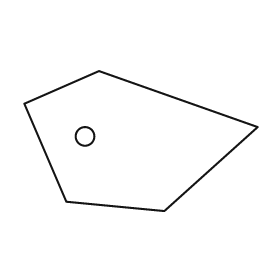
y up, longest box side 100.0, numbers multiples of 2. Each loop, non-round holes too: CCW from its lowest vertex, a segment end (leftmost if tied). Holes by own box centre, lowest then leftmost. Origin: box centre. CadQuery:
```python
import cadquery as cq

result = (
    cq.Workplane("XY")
    .moveTo(10.0, -30.0)
    .lineTo(50.0, 6.0)
    .lineTo(-18.0, 30.0)
    .lineTo(-50.0, 16.0)
    .lineTo(-32.0, -26.0)
    .close()
    .moveTo(-24.0, 2.0)
    .circle(4.0)
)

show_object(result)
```